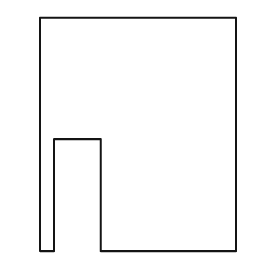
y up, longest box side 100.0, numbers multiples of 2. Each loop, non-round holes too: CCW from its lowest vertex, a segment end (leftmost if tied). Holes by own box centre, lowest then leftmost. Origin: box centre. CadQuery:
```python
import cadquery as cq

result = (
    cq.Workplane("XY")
    .moveTo(-42.0, -50.0)
    .lineTo(-36.0, -50.0)
    .lineTo(-36.0, -2.0)
    .lineTo(-16.0, -2.0)
    .lineTo(-16.0, -50.0)
    .lineTo(42.0, -50.0)
    .lineTo(42.0, 50.0)
    .lineTo(-42.0, 50.0)
    .close()
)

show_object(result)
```